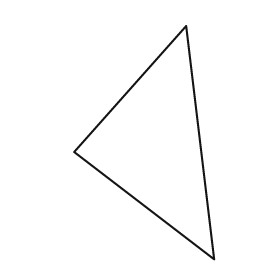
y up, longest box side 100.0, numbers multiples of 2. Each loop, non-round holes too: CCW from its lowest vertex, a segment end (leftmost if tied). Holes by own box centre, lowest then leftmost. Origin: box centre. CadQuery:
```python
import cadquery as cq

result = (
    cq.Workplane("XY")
    .moveTo(30.0, -50.0)
    .lineTo(18.0, 50.0)
    .lineTo(-30.0, -4.0)
    .close()
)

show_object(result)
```